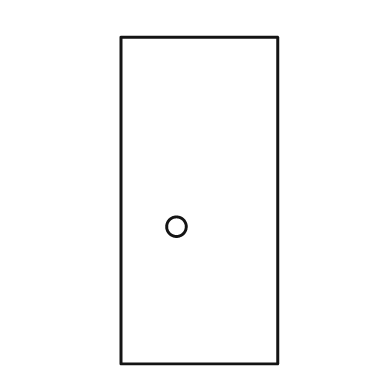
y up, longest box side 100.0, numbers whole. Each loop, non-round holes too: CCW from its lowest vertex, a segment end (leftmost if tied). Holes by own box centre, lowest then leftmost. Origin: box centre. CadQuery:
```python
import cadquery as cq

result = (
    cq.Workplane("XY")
    .moveTo(-24.0, -50.0)
    .lineTo(24.0, -50.0)
    .lineTo(24.0, 50.0)
    .lineTo(-24.0, 50.0)
    .close()
    .moveTo(-7.0, -8.0)
    .circle(3.0)
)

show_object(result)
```